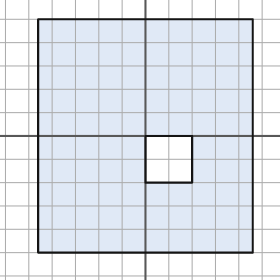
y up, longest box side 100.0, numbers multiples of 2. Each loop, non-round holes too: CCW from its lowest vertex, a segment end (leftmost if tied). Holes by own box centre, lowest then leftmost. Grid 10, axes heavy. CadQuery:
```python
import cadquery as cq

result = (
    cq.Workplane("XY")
    .moveTo(-46.0, -50.0)
    .lineTo(46.0, -50.0)
    .lineTo(46.0, 50.0)
    .lineTo(-46.0, 50.0)
    .close()
    .moveTo(0.0, -20.0)
    .lineTo(20.0, -20.0)
    .lineTo(20.0, 0.0)
    .lineTo(0.0, 0.0)
    .close()
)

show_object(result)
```